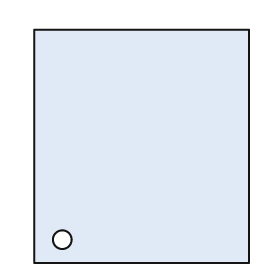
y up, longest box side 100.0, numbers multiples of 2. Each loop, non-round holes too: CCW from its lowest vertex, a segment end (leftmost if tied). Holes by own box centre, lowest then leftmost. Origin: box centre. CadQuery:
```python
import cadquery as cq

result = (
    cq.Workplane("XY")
    .moveTo(-46.0, -50.0)
    .lineTo(46.0, -50.0)
    .lineTo(46.0, 50.0)
    .lineTo(-46.0, 50.0)
    .close()
    .moveTo(-34.0, -40.0)
    .circle(4.0)
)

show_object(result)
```